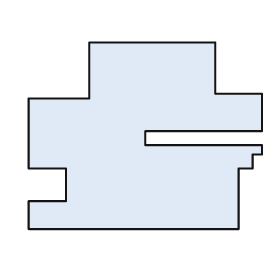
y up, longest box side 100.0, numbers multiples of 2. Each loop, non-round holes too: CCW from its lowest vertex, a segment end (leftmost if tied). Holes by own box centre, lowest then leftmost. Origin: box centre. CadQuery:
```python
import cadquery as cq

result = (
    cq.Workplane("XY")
    .moveTo(-50.0, -40.0)
    .lineTo(40.0, -40.0)
    .lineTo(40.0, -14.0)
    .lineTo(46.0, -14.0)
    .lineTo(46.0, -8.0)
    .lineTo(50.0, -8.0)
    .lineTo(50.0, -4.0)
    .lineTo(0.0, -4.0)
    .lineTo(0.0, 2.0)
    .lineTo(50.0, 2.0)
    .lineTo(50.0, 18.0)
    .lineTo(30.0, 18.0)
    .lineTo(30.0, 40.0)
    .lineTo(-24.0, 40.0)
    .lineTo(-24.0, 16.0)
    .lineTo(-50.0, 16.0)
    .lineTo(-50.0, -14.0)
    .lineTo(-34.0, -14.0)
    .lineTo(-34.0, -28.0)
    .lineTo(-50.0, -28.0)
    .close()
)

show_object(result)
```